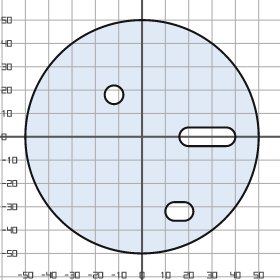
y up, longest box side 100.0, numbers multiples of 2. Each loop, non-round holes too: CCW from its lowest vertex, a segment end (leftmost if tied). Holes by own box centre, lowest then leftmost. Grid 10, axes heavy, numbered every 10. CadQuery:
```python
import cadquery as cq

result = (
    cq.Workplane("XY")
    .moveTo(0.0, 0.0)
    .circle(50.0)
    .moveTo(14.0, -36.0)
    .lineTo(18.0, -36.0)
    .threePointArc((22.0, -32.0), (18.0, -28.0))
    .lineTo(14.0, -28.0)
    .threePointArc((10.0, -32.0), (14.0, -36.0))
    .close()
    .moveTo(20.0, -4.0)
    .lineTo(36.0, -4.0)
    .threePointArc((40.0, 0.0), (36.0, 4.0))
    .lineTo(20.0, 4.0)
    .threePointArc((16.0, 0.0), (20.0, -4.0))
    .close()
    .moveTo(-12.0, 18.0)
    .circle(4.0)
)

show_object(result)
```